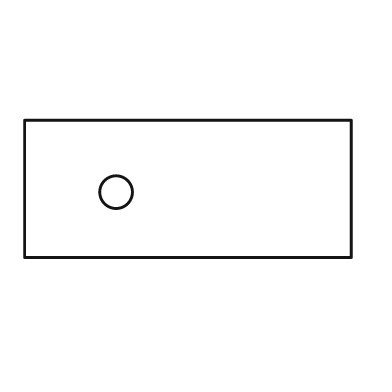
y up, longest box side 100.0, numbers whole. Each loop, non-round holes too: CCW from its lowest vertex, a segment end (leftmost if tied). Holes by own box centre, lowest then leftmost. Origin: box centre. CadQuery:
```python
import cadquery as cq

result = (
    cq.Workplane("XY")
    .moveTo(-50.0, -21.0)
    .lineTo(50.0, -21.0)
    .lineTo(50.0, 21.0)
    .lineTo(-50.0, 21.0)
    .close()
    .moveTo(-22.0, -1.0)
    .circle(5.0)
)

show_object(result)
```